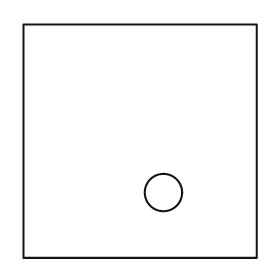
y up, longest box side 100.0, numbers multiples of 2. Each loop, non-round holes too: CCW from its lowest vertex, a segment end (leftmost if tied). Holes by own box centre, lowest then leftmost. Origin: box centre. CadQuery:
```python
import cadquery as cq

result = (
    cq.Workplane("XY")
    .moveTo(-50.0, -50.0)
    .lineTo(50.0, -50.0)
    .lineTo(50.0, 50.0)
    .lineTo(-50.0, 50.0)
    .close()
    .moveTo(10.0, -22.0)
    .circle(8.0)
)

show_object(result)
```